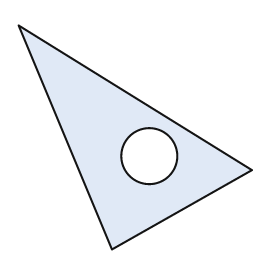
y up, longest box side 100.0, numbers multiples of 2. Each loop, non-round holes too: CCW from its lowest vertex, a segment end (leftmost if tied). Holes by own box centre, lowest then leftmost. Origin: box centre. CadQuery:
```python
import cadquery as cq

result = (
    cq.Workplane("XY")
    .moveTo(-10.0, -48.0)
    .lineTo(50.0, -14.0)
    .lineTo(-50.0, 48.0)
    .close()
    .moveTo(6.0, -8.0)
    .circle(12.0)
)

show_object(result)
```